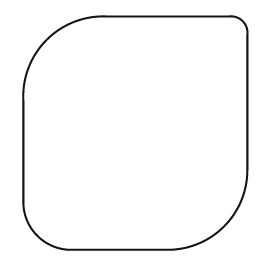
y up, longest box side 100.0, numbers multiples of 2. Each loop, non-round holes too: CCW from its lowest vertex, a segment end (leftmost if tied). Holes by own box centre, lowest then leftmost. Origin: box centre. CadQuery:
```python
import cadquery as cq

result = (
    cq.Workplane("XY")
    .moveTo(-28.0, -50.0)
    .lineTo(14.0, -50.0)
    .threePointArc((38.0, -40.0), (48.0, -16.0))
    .lineTo(48.0, 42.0)
    .threePointArc((46.0, 48.0), (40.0, 50.0))
    .lineTo(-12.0, 50.0)
    .threePointArc((-38.0, 40.0), (-48.0, 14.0))
    .lineTo(-48.0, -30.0)
    .threePointArc((-42.0, -44.0), (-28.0, -50.0))
    .close()
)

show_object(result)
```